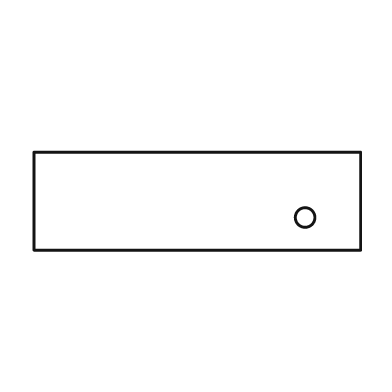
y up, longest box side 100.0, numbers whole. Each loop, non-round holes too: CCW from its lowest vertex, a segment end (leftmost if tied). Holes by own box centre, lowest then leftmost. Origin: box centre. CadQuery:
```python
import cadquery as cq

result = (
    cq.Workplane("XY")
    .moveTo(-50.0, -15.0)
    .lineTo(50.0, -15.0)
    .lineTo(50.0, 15.0)
    .lineTo(-50.0, 15.0)
    .close()
    .moveTo(33.0, -5.0)
    .circle(3.0)
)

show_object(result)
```